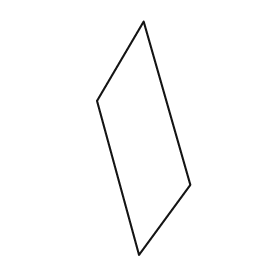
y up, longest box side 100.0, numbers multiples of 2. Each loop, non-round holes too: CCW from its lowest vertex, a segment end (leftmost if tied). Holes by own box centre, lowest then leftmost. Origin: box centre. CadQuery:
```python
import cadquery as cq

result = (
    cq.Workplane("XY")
    .moveTo(-2.0, -50.0)
    .lineTo(20.0, -20.0)
    .lineTo(0.0, 50.0)
    .lineTo(-20.0, 16.0)
    .close()
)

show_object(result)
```